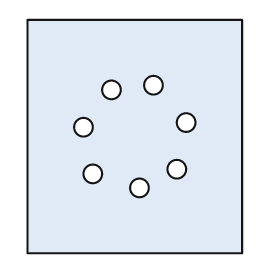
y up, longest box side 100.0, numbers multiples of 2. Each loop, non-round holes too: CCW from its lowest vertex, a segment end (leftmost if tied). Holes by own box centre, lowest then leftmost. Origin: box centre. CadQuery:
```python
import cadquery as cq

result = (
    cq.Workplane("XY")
    .moveTo(-46.0, -50.0)
    .lineTo(46.0, -50.0)
    .lineTo(46.0, 50.0)
    .lineTo(-46.0, 50.0)
    .close()
    .moveTo(2.0, -22.0)
    .circle(4.0)
    .moveTo(-18.0, -16.0)
    .circle(4.0)
    .moveTo(18.0, -14.0)
    .circle(4.0)
    .moveTo(-22.0, 4.0)
    .circle(4.0)
    .moveTo(22.0, 6.0)
    .circle(4.0)
    .moveTo(-10.0, 20.0)
    .circle(4.0)
    .moveTo(8.0, 22.0)
    .circle(4.0)
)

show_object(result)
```